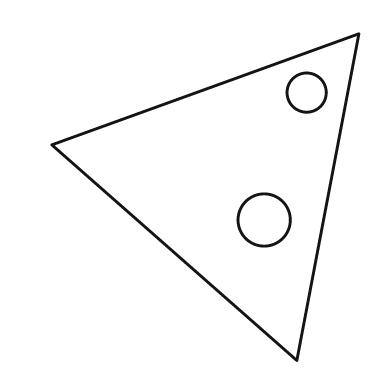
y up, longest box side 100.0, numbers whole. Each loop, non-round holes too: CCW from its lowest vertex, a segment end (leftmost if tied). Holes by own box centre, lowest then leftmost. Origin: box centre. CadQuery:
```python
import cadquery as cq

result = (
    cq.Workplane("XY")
    .moveTo(28.0, -50.0)
    .lineTo(47.0, 50.0)
    .lineTo(-47.0, 16.0)
    .close()
    .moveTo(18.0, -7.0)
    .circle(8.0)
    .moveTo(31.0, 32.0)
    .circle(6.0)
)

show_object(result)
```